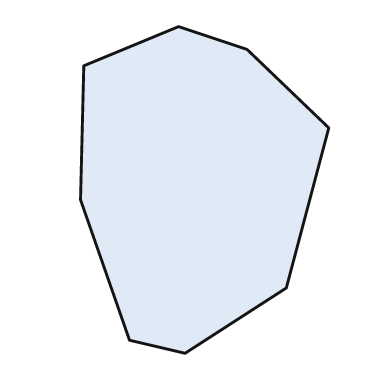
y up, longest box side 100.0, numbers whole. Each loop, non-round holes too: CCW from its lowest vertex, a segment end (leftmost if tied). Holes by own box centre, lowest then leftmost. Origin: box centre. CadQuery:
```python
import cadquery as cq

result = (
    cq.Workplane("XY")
    .moveTo(-6.0, -50.0)
    .lineTo(25.0, -30.0)
    .lineTo(38.0, 19.0)
    .lineTo(13.0, 43.0)
    .lineTo(-8.0, 50.0)
    .lineTo(-37.0, 38.0)
    .lineTo(-38.0, -3.0)
    .lineTo(-23.0, -46.0)
    .close()
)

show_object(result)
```